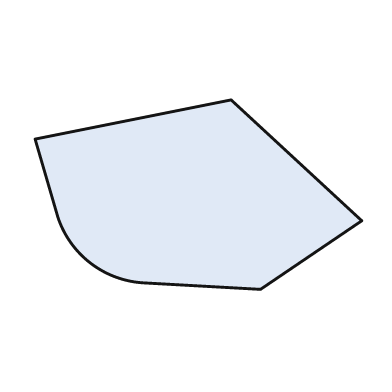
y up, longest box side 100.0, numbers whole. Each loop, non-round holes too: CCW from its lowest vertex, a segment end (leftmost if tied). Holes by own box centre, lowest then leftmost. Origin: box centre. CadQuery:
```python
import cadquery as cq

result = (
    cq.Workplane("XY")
    .moveTo(19.0, -29.0)
    .lineTo(50.0, -8.0)
    .lineTo(10.0, 29.0)
    .lineTo(-50.0, 17.0)
    .lineTo(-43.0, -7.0)
    .threePointArc((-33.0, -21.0), (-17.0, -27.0))
    .close()
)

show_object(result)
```